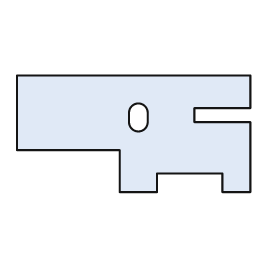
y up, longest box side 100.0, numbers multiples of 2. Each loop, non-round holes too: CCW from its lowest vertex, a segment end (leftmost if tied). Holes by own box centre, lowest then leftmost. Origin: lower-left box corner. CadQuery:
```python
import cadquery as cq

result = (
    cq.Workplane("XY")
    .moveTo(44.0, 0.0)
    .lineTo(60.0, 0.0)
    .lineTo(60.0, 8.0)
    .lineTo(88.0, 8.0)
    .lineTo(88.0, 0.0)
    .lineTo(100.0, 0.0)
    .lineTo(100.0, 30.0)
    .lineTo(76.0, 30.0)
    .lineTo(76.0, 36.0)
    .lineTo(100.0, 36.0)
    .lineTo(100.0, 50.0)
    .lineTo(0.0, 50.0)
    .lineTo(0.0, 18.0)
    .lineTo(44.0, 18.0)
    .close()
    .moveTo(48.0, 30.0)
    .threePointArc((52.0, 26.0), (56.0, 30.0))
    .lineTo(56.0, 34.0)
    .threePointArc((52.0, 38.0), (48.0, 34.0))
    .close()
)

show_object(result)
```